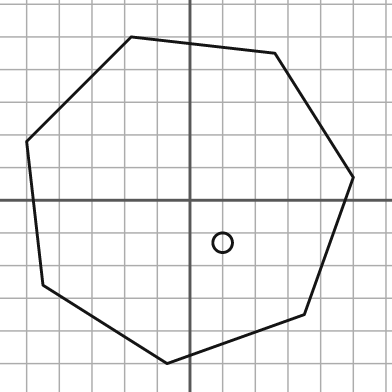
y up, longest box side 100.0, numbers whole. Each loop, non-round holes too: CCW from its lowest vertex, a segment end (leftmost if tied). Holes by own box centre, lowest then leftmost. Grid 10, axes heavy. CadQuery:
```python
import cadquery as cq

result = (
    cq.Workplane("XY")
    .moveTo(-7.0, -50.0)
    .lineTo(35.0, -35.0)
    .lineTo(50.0, 7.0)
    .lineTo(26.0, 45.0)
    .lineTo(-18.0, 50.0)
    .lineTo(-50.0, 18.0)
    .lineTo(-45.0, -26.0)
    .close()
    .moveTo(10.0, -13.0)
    .circle(3.0)
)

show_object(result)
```